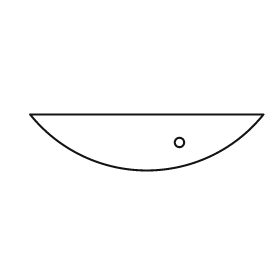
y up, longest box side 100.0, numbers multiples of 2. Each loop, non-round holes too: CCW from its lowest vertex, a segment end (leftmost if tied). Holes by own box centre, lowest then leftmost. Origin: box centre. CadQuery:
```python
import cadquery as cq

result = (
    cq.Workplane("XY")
    .moveTo(-50.0, 12.0)
    .threePointArc((0.0, -12.0), (50.0, 12.0))
    .close()
    .moveTo(14.0, 0.0)
    .circle(2.0)
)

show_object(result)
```